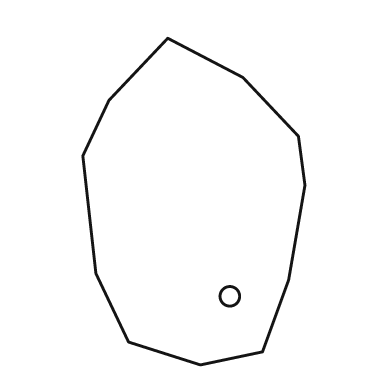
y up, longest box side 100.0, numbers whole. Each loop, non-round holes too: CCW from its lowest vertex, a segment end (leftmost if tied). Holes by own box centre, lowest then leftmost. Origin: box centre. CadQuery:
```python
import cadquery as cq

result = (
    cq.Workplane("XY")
    .moveTo(2.0, -50.0)
    .lineTo(21.0, -46.0)
    .lineTo(29.0, -24.0)
    .lineTo(34.0, 5.0)
    .lineTo(32.0, 20.0)
    .lineTo(15.0, 38.0)
    .lineTo(-8.0, 50.0)
    .lineTo(-26.0, 31.0)
    .lineTo(-34.0, 14.0)
    .lineTo(-30.0, -22.0)
    .lineTo(-20.0, -43.0)
    .close()
    .moveTo(11.0, -29.0)
    .circle(3.0)
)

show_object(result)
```